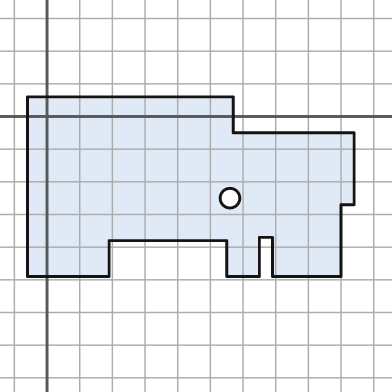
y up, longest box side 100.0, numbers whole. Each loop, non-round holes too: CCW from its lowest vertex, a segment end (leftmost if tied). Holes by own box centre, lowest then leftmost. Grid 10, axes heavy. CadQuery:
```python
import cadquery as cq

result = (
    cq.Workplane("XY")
    .moveTo(-6.0, -49.0)
    .lineTo(19.0, -49.0)
    .lineTo(19.0, -38.0)
    .lineTo(55.0, -38.0)
    .lineTo(55.0, -49.0)
    .lineTo(65.0, -49.0)
    .lineTo(65.0, -37.0)
    .lineTo(69.0, -37.0)
    .lineTo(69.0, -49.0)
    .lineTo(90.0, -49.0)
    .lineTo(90.0, -27.0)
    .lineTo(94.0, -27.0)
    .lineTo(94.0, -5.0)
    .lineTo(57.0, -5.0)
    .lineTo(57.0, 6.0)
    .lineTo(-6.0, 6.0)
    .close()
    .moveTo(56.0, -25.0)
    .circle(3.0)
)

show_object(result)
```